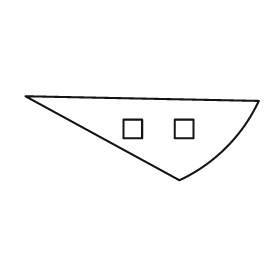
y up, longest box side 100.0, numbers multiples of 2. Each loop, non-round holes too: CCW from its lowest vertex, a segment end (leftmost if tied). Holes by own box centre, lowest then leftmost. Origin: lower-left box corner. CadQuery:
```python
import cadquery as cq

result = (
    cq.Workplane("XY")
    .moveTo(66.0, 0.0)
    .threePointArc((86.0, 14.0), (100.0, 34.0))
    .lineTo(0.0, 36.0)
    .close()
    .moveTo(42.0, 18.0)
    .lineTo(50.0, 18.0)
    .lineTo(50.0, 26.0)
    .lineTo(42.0, 26.0)
    .close()
    .moveTo(64.0, 18.0)
    .lineTo(72.0, 18.0)
    .lineTo(72.0, 26.0)
    .lineTo(64.0, 26.0)
    .close()
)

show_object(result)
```